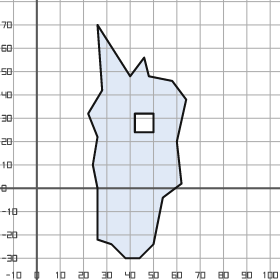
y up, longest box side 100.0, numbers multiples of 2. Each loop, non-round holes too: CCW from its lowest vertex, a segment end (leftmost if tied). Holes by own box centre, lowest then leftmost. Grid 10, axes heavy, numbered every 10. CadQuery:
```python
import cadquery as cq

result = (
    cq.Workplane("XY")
    .moveTo(38.0, -30.0)
    .lineTo(44.0, -30.0)
    .lineTo(50.0, -24.0)
    .lineTo(54.0, -4.0)
    .lineTo(62.0, 2.0)
    .lineTo(60.0, 20.0)
    .lineTo(64.0, 38.0)
    .lineTo(58.0, 46.0)
    .lineTo(48.0, 48.0)
    .lineTo(46.0, 56.0)
    .lineTo(40.0, 48.0)
    .lineTo(26.0, 70.0)
    .lineTo(28.0, 42.0)
    .lineTo(22.0, 32.0)
    .lineTo(26.0, 22.0)
    .lineTo(24.0, 10.0)
    .lineTo(26.0, 0.0)
    .lineTo(26.0, -22.0)
    .lineTo(32.0, -24.0)
    .close()
    .moveTo(42.0, 24.0)
    .lineTo(50.0, 24.0)
    .lineTo(50.0, 32.0)
    .lineTo(42.0, 32.0)
    .close()
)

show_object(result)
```